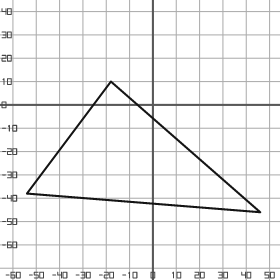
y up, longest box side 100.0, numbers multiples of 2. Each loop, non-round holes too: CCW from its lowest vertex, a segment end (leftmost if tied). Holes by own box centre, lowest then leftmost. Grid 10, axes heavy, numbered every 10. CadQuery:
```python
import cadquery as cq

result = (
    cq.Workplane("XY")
    .moveTo(46.0, -46.0)
    .lineTo(-18.0, 10.0)
    .lineTo(-54.0, -38.0)
    .close()
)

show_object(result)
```